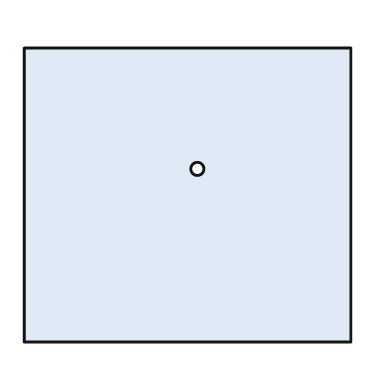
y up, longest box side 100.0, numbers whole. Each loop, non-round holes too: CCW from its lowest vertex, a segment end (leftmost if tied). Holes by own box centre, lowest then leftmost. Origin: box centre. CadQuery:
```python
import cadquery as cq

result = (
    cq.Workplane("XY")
    .moveTo(-50.0, -45.0)
    .lineTo(50.0, -45.0)
    .lineTo(50.0, 45.0)
    .lineTo(-50.0, 45.0)
    .close()
    .moveTo(3.0, 8.0)
    .circle(2.0)
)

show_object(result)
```